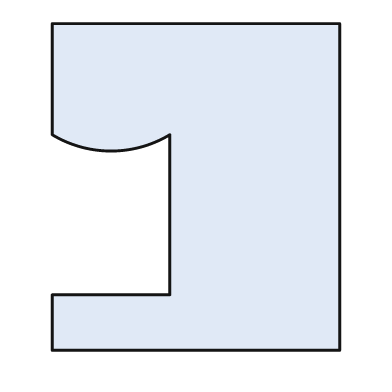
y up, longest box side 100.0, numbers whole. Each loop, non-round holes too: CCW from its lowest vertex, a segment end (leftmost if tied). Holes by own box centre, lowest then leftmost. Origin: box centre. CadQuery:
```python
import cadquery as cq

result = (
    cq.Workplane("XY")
    .moveTo(-44.0, -50.0)
    .lineTo(44.0, -50.0)
    .lineTo(44.0, 50.0)
    .lineTo(-44.0, 50.0)
    .lineTo(-44.0, 16.0)
    .threePointArc((-26.0, 11.0), (-8.0, 16.0))
    .lineTo(-8.0, -33.0)
    .lineTo(-44.0, -33.0)
    .close()
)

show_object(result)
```